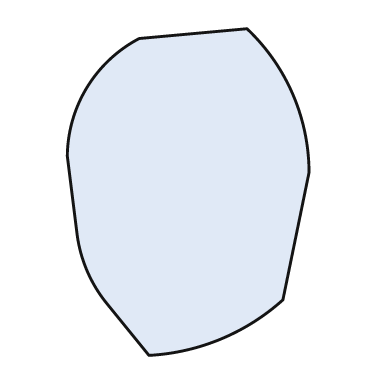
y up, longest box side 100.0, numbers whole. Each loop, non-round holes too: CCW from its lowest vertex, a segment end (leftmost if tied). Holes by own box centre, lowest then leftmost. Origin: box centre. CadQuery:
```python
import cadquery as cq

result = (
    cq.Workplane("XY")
    .moveTo(-12.0, -50.0)
    .threePointArc((10.0, -45.0), (29.0, -33.0))
    .lineTo(37.0, 6.0)
    .threePointArc((32.0, 30.0), (18.0, 50.0))
    .lineTo(-15.0, 47.0)
    .threePointArc((-31.0, 32.0), (-37.0, 11.0))
    .lineTo(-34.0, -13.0)
    .threePointArc((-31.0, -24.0), (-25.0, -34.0))
    .close()
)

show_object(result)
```